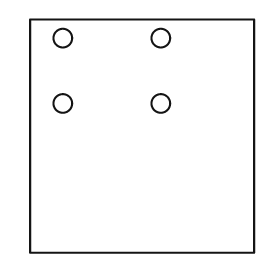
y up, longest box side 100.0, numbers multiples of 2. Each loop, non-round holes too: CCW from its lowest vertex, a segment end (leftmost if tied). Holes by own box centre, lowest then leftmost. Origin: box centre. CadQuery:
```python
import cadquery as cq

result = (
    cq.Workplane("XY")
    .moveTo(-48.0, -50.0)
    .lineTo(48.0, -50.0)
    .lineTo(48.0, 50.0)
    .lineTo(-48.0, 50.0)
    .close()
    .moveTo(-34.0, 14.0)
    .circle(4.0)
    .moveTo(8.0, 14.0)
    .circle(4.0)
    .moveTo(-34.0, 42.0)
    .circle(4.0)
    .moveTo(8.0, 42.0)
    .circle(4.0)
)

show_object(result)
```